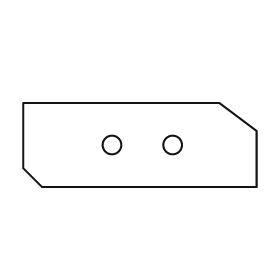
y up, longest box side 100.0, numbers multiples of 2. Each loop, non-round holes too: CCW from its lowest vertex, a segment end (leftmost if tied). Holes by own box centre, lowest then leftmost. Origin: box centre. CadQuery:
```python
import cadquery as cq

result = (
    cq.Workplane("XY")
    .moveTo(-42.0, -18.0)
    .lineTo(50.0, -18.0)
    .lineTo(50.0, 6.0)
    .lineTo(34.0, 18.0)
    .lineTo(-50.0, 18.0)
    .lineTo(-50.0, -10.0)
    .close()
    .moveTo(-12.0, 0.0)
    .circle(4.0)
    .moveTo(14.0, 0.0)
    .circle(4.0)
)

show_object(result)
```